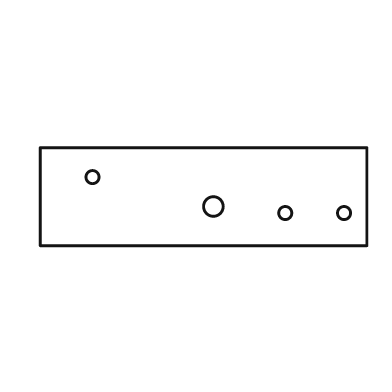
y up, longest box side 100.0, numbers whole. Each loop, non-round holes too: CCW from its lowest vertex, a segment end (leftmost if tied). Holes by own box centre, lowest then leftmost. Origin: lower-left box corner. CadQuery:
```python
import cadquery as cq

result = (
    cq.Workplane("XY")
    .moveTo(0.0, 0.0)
    .lineTo(100.0, 0.0)
    .lineTo(100.0, 30.0)
    .lineTo(0.0, 30.0)
    .close()
    .moveTo(75.0, 10.0)
    .circle(2.0)
    .moveTo(93.0, 10.0)
    .circle(2.0)
    .moveTo(53.0, 12.0)
    .circle(3.0)
    .moveTo(16.0, 21.0)
    .circle(2.0)
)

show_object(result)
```